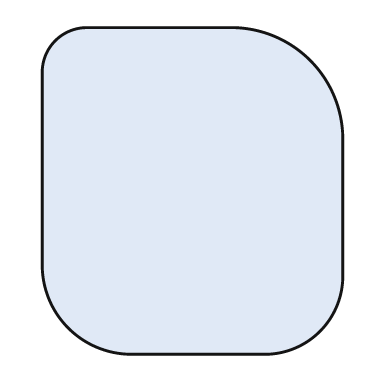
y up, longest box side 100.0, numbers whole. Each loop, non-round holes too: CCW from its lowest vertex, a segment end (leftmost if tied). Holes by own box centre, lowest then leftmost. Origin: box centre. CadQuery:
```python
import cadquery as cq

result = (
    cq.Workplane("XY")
    .moveTo(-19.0, -50.0)
    .lineTo(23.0, -50.0)
    .threePointArc((39.0, -43.0), (46.0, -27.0))
    .lineTo(46.0, 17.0)
    .threePointArc((36.0, 40.0), (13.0, 50.0))
    .lineTo(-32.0, 50.0)
    .threePointArc((-42.0, 46.0), (-46.0, 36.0))
    .lineTo(-46.0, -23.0)
    .threePointArc((-38.0, -42.0), (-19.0, -50.0))
    .close()
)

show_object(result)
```